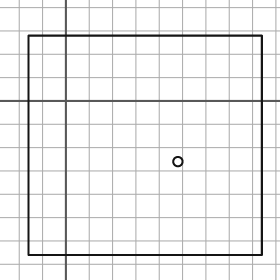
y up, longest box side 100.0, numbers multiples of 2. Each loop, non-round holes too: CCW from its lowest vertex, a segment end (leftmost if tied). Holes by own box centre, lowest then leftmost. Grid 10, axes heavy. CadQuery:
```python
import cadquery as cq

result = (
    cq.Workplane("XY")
    .moveTo(-16.0, -66.0)
    .lineTo(84.0, -66.0)
    .lineTo(84.0, 28.0)
    .lineTo(-16.0, 28.0)
    .close()
    .moveTo(48.0, -26.0)
    .circle(2.0)
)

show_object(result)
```